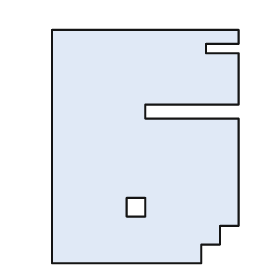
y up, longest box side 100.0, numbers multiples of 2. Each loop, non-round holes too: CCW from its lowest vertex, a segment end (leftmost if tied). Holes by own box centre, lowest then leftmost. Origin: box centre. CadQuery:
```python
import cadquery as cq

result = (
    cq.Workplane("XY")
    .moveTo(-40.0, -50.0)
    .lineTo(24.0, -50.0)
    .lineTo(24.0, -42.0)
    .lineTo(32.0, -42.0)
    .lineTo(32.0, -34.0)
    .lineTo(40.0, -34.0)
    .lineTo(40.0, 12.0)
    .lineTo(0.0, 12.0)
    .lineTo(0.0, 18.0)
    .lineTo(40.0, 18.0)
    .lineTo(40.0, 40.0)
    .lineTo(26.0, 40.0)
    .lineTo(26.0, 44.0)
    .lineTo(40.0, 44.0)
    .lineTo(40.0, 50.0)
    .lineTo(-40.0, 50.0)
    .close()
    .moveTo(-8.0, -30.0)
    .lineTo(0.0, -30.0)
    .lineTo(0.0, -22.0)
    .lineTo(-8.0, -22.0)
    .close()
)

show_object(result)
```